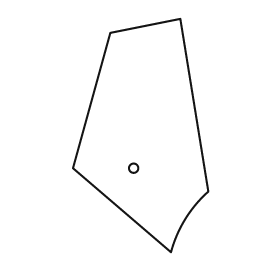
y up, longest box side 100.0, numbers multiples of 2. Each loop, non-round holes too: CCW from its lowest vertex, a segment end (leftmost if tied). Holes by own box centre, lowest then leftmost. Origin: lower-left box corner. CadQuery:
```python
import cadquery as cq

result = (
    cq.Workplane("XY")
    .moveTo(42.0, 0.0)
    .threePointArc((48.0, 14.0), (58.0, 26.0))
    .lineTo(46.0, 100.0)
    .lineTo(16.0, 94.0)
    .lineTo(0.0, 36.0)
    .close()
    .moveTo(26.0, 36.0)
    .circle(2.0)
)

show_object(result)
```